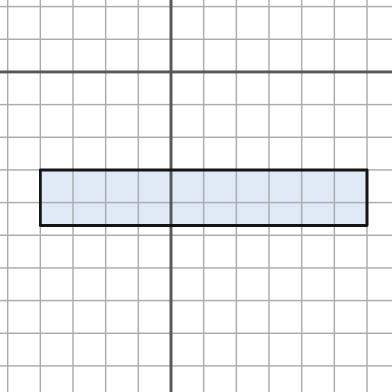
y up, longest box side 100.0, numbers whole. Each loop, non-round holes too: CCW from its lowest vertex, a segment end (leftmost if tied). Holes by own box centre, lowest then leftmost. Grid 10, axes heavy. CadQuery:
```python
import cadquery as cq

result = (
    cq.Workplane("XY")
    .moveTo(-40.0, -47.0)
    .lineTo(60.0, -47.0)
    .lineTo(60.0, -30.0)
    .lineTo(-40.0, -30.0)
    .close()
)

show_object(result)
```